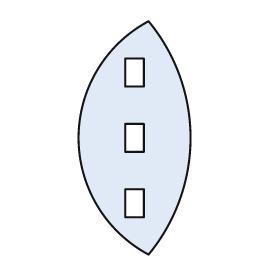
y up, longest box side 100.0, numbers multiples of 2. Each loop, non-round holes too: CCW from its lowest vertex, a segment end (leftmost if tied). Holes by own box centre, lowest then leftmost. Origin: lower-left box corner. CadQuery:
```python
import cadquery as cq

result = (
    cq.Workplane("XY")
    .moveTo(30.0, 0.0)
    .threePointArc((48.0, 50.0), (30.0, 100.0))
    .threePointArc((0.0, 50.0), (30.0, 0.0))
    .close()
    .moveTo(20.0, 16.0)
    .lineTo(28.0, 16.0)
    .lineTo(28.0, 28.0)
    .lineTo(20.0, 28.0)
    .close()
    .moveTo(20.0, 44.0)
    .lineTo(28.0, 44.0)
    .lineTo(28.0, 56.0)
    .lineTo(20.0, 56.0)
    .close()
    .moveTo(20.0, 72.0)
    .lineTo(28.0, 72.0)
    .lineTo(28.0, 84.0)
    .lineTo(20.0, 84.0)
    .close()
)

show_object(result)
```